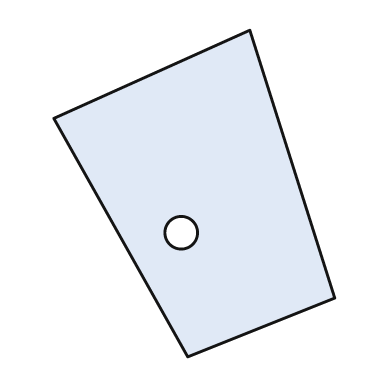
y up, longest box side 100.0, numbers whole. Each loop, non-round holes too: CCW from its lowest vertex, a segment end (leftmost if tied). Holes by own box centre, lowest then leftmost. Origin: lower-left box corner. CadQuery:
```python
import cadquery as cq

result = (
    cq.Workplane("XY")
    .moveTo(41.0, 0.0)
    .lineTo(86.0, 18.0)
    .lineTo(60.0, 100.0)
    .lineTo(0.0, 73.0)
    .close()
    .moveTo(39.0, 38.0)
    .circle(5.0)
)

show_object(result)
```